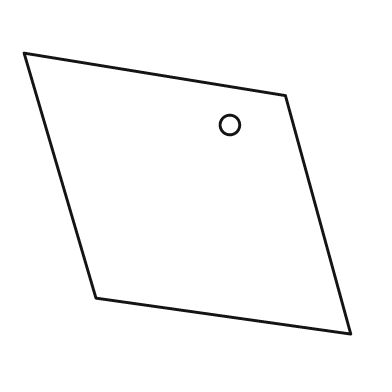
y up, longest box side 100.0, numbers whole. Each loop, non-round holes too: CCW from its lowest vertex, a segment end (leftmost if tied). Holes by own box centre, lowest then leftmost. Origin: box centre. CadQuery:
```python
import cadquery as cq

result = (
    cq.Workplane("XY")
    .moveTo(50.0, -43.0)
    .lineTo(30.0, 30.0)
    .lineTo(-50.0, 43.0)
    .lineTo(-28.0, -32.0)
    .close()
    .moveTo(13.0, 21.0)
    .circle(3.0)
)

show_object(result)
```